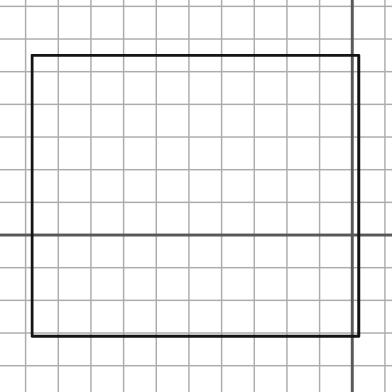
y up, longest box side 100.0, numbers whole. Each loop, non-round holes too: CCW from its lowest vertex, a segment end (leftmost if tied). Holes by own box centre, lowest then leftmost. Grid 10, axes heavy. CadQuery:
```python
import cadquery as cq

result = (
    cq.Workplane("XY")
    .moveTo(-98.0, -31.0)
    .lineTo(2.0, -31.0)
    .lineTo(2.0, 55.0)
    .lineTo(-98.0, 55.0)
    .close()
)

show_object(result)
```